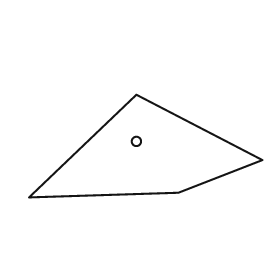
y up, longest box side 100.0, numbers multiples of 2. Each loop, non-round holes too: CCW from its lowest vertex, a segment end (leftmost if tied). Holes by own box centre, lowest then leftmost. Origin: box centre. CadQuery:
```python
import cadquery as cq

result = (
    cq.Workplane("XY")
    .moveTo(-50.0, -22.0)
    .lineTo(14.0, -20.0)
    .lineTo(50.0, -6.0)
    .lineTo(-4.0, 22.0)
    .close()
    .moveTo(-4.0, 2.0)
    .circle(2.0)
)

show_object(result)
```